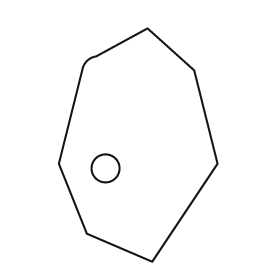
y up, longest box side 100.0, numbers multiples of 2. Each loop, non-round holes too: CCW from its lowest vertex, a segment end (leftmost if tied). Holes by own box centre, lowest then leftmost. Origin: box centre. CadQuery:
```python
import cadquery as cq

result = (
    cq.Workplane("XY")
    .moveTo(6.0, -50.0)
    .lineTo(34.0, -8.0)
    .lineTo(24.0, 32.0)
    .lineTo(4.0, 50.0)
    .lineTo(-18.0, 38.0)
    .threePointArc((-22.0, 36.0), (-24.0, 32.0))
    .lineTo(-34.0, -8.0)
    .lineTo(-22.0, -38.0)
    .close()
    .moveTo(-14.0, -10.0)
    .circle(6.0)
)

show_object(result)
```